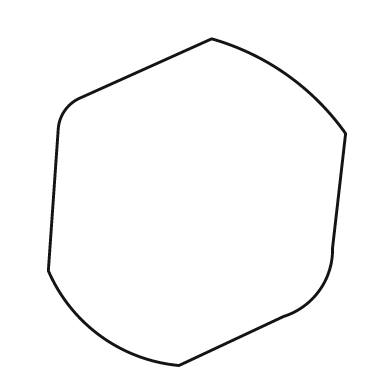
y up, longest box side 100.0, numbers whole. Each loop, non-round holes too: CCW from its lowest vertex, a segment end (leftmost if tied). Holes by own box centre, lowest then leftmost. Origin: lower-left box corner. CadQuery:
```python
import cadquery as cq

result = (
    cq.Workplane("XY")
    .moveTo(40.0, 0.0)
    .lineTo(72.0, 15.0)
    .threePointArc((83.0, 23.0), (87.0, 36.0))
    .lineTo(91.0, 71.0)
    .threePointArc((73.0, 89.0), (50.0, 100.0))
    .lineTo(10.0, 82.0)
    .threePointArc((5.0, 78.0), (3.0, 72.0))
    .lineTo(0.0, 29.0)
    .threePointArc((16.0, 9.0), (40.0, 0.0))
    .close()
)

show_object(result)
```